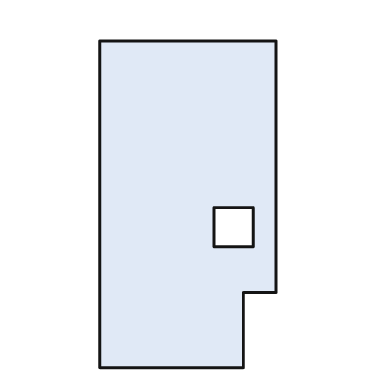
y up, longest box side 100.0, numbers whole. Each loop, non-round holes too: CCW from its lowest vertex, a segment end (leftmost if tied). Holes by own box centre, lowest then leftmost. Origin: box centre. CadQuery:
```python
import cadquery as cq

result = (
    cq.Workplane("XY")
    .moveTo(-27.0, -50.0)
    .lineTo(17.0, -50.0)
    .lineTo(17.0, -27.0)
    .lineTo(27.0, -27.0)
    .lineTo(27.0, 50.0)
    .lineTo(-27.0, 50.0)
    .close()
    .moveTo(8.0, -13.0)
    .lineTo(20.0, -13.0)
    .lineTo(20.0, -1.0)
    .lineTo(8.0, -1.0)
    .close()
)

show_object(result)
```